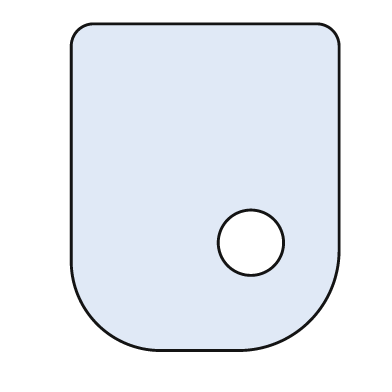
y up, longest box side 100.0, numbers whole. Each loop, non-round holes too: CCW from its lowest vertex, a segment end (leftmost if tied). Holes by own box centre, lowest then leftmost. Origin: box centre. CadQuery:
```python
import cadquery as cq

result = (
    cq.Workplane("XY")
    .moveTo(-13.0, -50.0)
    .lineTo(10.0, -50.0)
    .threePointArc((32.0, -41.0), (41.0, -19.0))
    .lineTo(41.0, 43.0)
    .threePointArc((39.0, 48.0), (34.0, 50.0))
    .lineTo(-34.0, 50.0)
    .threePointArc((-39.0, 48.0), (-41.0, 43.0))
    .lineTo(-41.0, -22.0)
    .threePointArc((-33.0, -42.0), (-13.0, -50.0))
    .close()
    .moveTo(14.0, -17.0)
    .circle(10.0)
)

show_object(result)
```